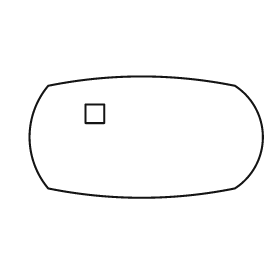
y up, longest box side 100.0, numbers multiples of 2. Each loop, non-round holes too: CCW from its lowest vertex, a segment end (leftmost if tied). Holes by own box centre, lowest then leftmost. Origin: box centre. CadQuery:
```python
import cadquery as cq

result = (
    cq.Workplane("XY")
    .moveTo(-42.0, -22.0)
    .threePointArc((-2.0, -26.0), (38.0, -22.0))
    .threePointArc((50.0, 0.0), (38.0, 22.0))
    .threePointArc((-2.0, 26.0), (-42.0, 22.0))
    .threePointArc((-50.0, 0.0), (-42.0, -22.0))
    .close()
    .moveTo(-26.0, 6.0)
    .lineTo(-18.0, 6.0)
    .lineTo(-18.0, 14.0)
    .lineTo(-26.0, 14.0)
    .close()
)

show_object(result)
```